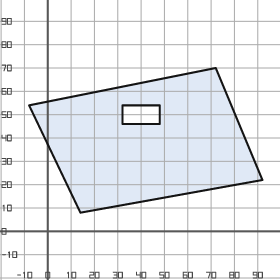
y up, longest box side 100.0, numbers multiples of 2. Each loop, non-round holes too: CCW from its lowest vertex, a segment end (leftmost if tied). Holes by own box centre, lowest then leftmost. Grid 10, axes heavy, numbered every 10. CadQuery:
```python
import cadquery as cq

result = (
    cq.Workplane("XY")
    .moveTo(14.0, 8.0)
    .lineTo(92.0, 22.0)
    .lineTo(72.0, 70.0)
    .lineTo(-8.0, 54.0)
    .close()
    .moveTo(32.0, 46.0)
    .lineTo(48.0, 46.0)
    .lineTo(48.0, 54.0)
    .lineTo(32.0, 54.0)
    .close()
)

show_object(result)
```